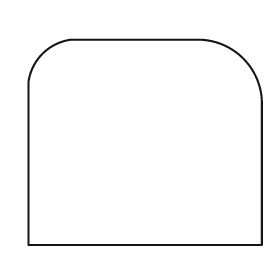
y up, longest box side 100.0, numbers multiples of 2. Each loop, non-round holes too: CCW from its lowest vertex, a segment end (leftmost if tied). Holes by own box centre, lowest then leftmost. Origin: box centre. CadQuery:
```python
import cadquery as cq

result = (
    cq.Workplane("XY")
    .moveTo(-50.0, -44.0)
    .lineTo(50.0, -44.0)
    .lineTo(50.0, 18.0)
    .threePointArc((42.0, 36.0), (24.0, 44.0))
    .lineTo(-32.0, 44.0)
    .threePointArc((-44.0, 38.0), (-50.0, 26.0))
    .close()
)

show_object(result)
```